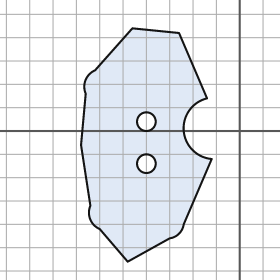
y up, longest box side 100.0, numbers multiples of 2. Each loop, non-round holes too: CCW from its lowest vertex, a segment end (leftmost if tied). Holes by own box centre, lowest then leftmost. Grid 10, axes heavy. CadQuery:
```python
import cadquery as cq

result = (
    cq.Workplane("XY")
    .moveTo(-48.0, -56.0)
    .lineTo(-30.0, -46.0)
    .threePointArc((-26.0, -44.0), (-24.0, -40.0))
    .lineTo(-12.0, -12.0)
    .threePointArc((-24.0, 0.0), (-14.0, 14.0))
    .lineTo(-26.0, 42.0)
    .lineTo(-46.0, 44.0)
    .lineTo(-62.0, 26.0)
    .threePointArc((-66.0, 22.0), (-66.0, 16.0))
    .lineTo(-68.0, -6.0)
    .lineTo(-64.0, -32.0)
    .threePointArc((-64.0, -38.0), (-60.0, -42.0))
    .close()
    .moveTo(-40.0, -14.0)
    .circle(4.0)
    .moveTo(-40.0, 4.0)
    .circle(4.0)
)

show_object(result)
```